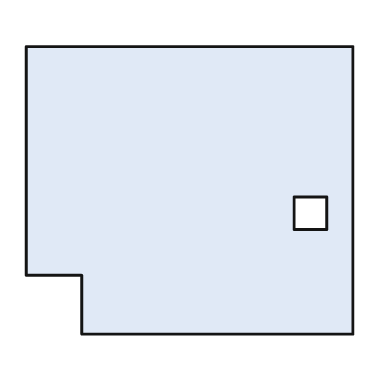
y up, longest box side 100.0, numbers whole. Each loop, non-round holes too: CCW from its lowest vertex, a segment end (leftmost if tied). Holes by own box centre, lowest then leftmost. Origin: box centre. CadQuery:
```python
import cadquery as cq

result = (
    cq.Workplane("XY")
    .moveTo(-33.0, -44.0)
    .lineTo(50.0, -44.0)
    .lineTo(50.0, 44.0)
    .lineTo(-50.0, 44.0)
    .lineTo(-50.0, -26.0)
    .lineTo(-33.0, -26.0)
    .close()
    .moveTo(32.0, -12.0)
    .lineTo(42.0, -12.0)
    .lineTo(42.0, -2.0)
    .lineTo(32.0, -2.0)
    .close()
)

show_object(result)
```